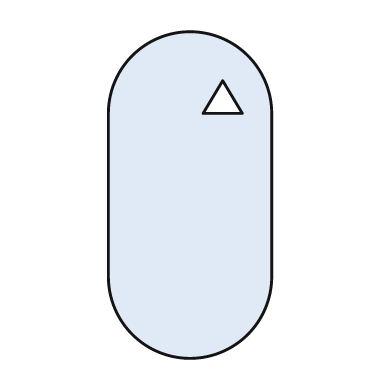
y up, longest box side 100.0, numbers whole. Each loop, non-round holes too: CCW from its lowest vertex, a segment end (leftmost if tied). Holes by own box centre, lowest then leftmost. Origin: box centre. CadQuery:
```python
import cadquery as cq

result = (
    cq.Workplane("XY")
    .moveTo(-25.0, -25.0)
    .threePointArc((0.0, -50.0), (25.0, -25.0))
    .lineTo(25.0, 25.0)
    .threePointArc((0.0, 50.0), (-25.0, 25.0))
    .close()
    .moveTo(4.0, 25.0)
    .lineTo(16.0, 25.0)
    .lineTo(10.0, 35.0)
    .close()
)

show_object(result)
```